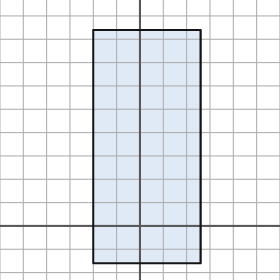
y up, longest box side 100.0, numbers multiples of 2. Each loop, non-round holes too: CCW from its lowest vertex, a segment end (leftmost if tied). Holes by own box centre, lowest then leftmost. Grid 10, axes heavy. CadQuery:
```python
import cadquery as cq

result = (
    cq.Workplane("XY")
    .moveTo(-20.0, -16.0)
    .lineTo(26.0, -16.0)
    .lineTo(26.0, 84.0)
    .lineTo(-20.0, 84.0)
    .close()
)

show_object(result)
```